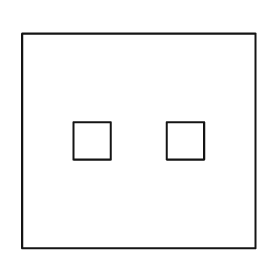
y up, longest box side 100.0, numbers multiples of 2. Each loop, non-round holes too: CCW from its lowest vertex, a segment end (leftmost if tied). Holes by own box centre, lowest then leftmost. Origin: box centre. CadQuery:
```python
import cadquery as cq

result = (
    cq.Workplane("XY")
    .moveTo(-50.0, -46.0)
    .lineTo(50.0, -46.0)
    .lineTo(50.0, 46.0)
    .lineTo(-50.0, 46.0)
    .close()
    .moveTo(-28.0, -8.0)
    .lineTo(-12.0, -8.0)
    .lineTo(-12.0, 8.0)
    .lineTo(-28.0, 8.0)
    .close()
    .moveTo(12.0, -8.0)
    .lineTo(28.0, -8.0)
    .lineTo(28.0, 8.0)
    .lineTo(12.0, 8.0)
    .close()
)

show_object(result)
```